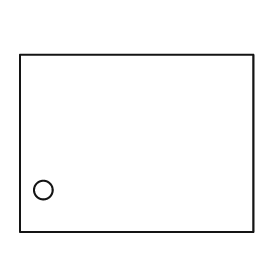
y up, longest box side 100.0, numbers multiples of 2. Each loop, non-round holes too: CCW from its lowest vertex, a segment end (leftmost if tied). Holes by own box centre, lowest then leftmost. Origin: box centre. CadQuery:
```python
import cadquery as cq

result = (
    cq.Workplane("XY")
    .moveTo(-50.0, -38.0)
    .lineTo(50.0, -38.0)
    .lineTo(50.0, 38.0)
    .lineTo(-50.0, 38.0)
    .close()
    .moveTo(-40.0, -20.0)
    .circle(4.0)
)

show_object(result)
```